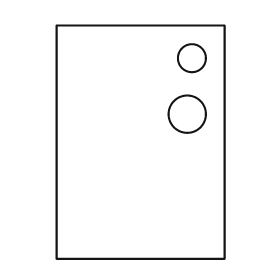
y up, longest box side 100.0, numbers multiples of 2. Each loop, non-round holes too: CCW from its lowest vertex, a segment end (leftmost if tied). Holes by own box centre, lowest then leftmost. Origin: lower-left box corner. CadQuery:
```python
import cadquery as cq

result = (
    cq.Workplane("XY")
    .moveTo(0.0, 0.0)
    .lineTo(72.0, 0.0)
    .lineTo(72.0, 100.0)
    .lineTo(0.0, 100.0)
    .close()
    .moveTo(56.0, 62.0)
    .circle(8.0)
    .moveTo(58.0, 86.0)
    .circle(6.0)
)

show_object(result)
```